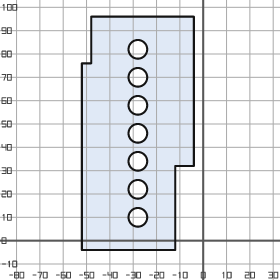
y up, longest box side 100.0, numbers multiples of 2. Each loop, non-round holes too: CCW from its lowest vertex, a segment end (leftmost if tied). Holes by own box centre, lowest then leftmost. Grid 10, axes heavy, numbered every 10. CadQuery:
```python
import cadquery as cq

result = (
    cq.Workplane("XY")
    .moveTo(-52.0, -4.0)
    .lineTo(-12.0, -4.0)
    .lineTo(-12.0, 32.0)
    .lineTo(-4.0, 32.0)
    .lineTo(-4.0, 96.0)
    .lineTo(-48.0, 96.0)
    .lineTo(-48.0, 76.0)
    .lineTo(-52.0, 76.0)
    .close()
    .moveTo(-28.0, 10.0)
    .circle(4.0)
    .moveTo(-28.0, 22.0)
    .circle(4.0)
    .moveTo(-28.0, 34.0)
    .circle(4.0)
    .moveTo(-28.0, 46.0)
    .circle(4.0)
    .moveTo(-28.0, 58.0)
    .circle(4.0)
    .moveTo(-28.0, 70.0)
    .circle(4.0)
    .moveTo(-28.0, 82.0)
    .circle(4.0)
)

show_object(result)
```